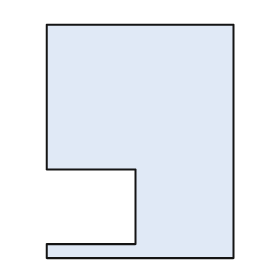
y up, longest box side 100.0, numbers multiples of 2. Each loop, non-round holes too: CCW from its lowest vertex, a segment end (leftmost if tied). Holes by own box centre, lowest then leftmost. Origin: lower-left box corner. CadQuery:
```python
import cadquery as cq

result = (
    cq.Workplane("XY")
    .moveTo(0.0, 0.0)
    .lineTo(80.0, 0.0)
    .lineTo(80.0, 100.0)
    .lineTo(0.0, 100.0)
    .lineTo(0.0, 38.0)
    .lineTo(38.0, 38.0)
    .lineTo(38.0, 6.0)
    .lineTo(0.0, 6.0)
    .close()
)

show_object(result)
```